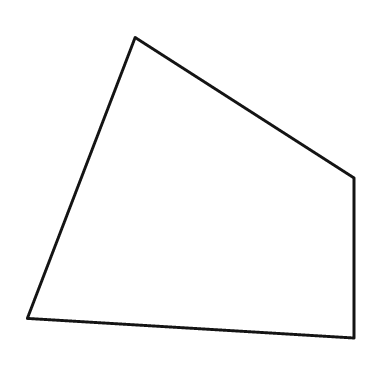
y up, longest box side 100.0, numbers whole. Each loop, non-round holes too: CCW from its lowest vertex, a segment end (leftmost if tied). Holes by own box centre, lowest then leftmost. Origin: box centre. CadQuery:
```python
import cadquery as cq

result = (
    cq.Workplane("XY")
    .moveTo(50.0, -46.0)
    .lineTo(50.0, 3.0)
    .lineTo(-17.0, 46.0)
    .lineTo(-50.0, -40.0)
    .close()
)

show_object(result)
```